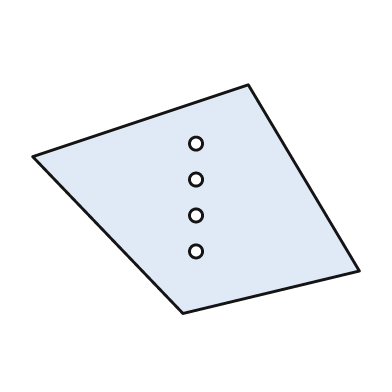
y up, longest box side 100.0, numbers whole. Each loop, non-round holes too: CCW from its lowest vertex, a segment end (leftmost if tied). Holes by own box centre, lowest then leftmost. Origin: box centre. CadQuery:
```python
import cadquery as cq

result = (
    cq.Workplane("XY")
    .moveTo(-4.0, -35.0)
    .lineTo(50.0, -22.0)
    .lineTo(16.0, 35.0)
    .lineTo(-50.0, 13.0)
    .close()
    .moveTo(0.0, -16.0)
    .circle(2.0)
    .moveTo(0.0, -5.0)
    .circle(2.0)
    .moveTo(0.0, 6.0)
    .circle(2.0)
    .moveTo(0.0, 17.0)
    .circle(2.0)
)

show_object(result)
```